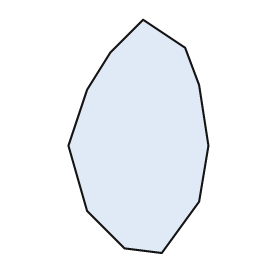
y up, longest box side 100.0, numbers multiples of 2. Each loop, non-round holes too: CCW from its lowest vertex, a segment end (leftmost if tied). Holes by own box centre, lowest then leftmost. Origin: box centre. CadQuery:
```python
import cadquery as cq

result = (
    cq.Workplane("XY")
    .moveTo(10.0, -50.0)
    .lineTo(26.0, -28.0)
    .lineTo(30.0, -4.0)
    .lineTo(26.0, 22.0)
    .lineTo(20.0, 38.0)
    .lineTo(2.0, 50.0)
    .lineTo(-12.0, 36.0)
    .lineTo(-22.0, 20.0)
    .lineTo(-30.0, -4.0)
    .lineTo(-22.0, -32.0)
    .lineTo(-6.0, -48.0)
    .close()
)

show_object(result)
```